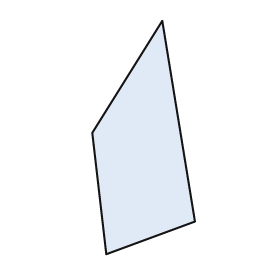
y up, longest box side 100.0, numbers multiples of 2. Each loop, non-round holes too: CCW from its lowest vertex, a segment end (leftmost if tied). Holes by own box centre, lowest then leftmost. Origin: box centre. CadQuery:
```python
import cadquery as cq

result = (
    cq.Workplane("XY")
    .moveTo(-16.0, -50.0)
    .lineTo(22.0, -36.0)
    .lineTo(8.0, 50.0)
    .lineTo(-22.0, 2.0)
    .close()
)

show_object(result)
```